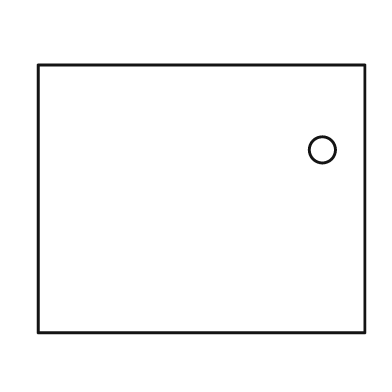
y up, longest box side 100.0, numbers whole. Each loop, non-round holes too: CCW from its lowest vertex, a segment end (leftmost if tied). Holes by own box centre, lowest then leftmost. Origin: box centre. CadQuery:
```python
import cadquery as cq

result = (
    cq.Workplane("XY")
    .moveTo(-50.0, -41.0)
    .lineTo(50.0, -41.0)
    .lineTo(50.0, 41.0)
    .lineTo(-50.0, 41.0)
    .close()
    .moveTo(37.0, 15.0)
    .circle(4.0)
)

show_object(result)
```